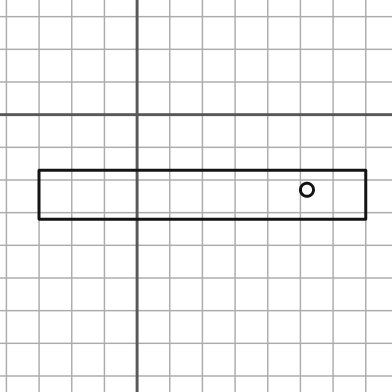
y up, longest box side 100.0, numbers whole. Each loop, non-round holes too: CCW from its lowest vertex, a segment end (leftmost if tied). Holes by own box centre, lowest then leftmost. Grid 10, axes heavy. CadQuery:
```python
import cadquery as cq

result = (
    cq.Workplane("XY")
    .moveTo(-30.0, -32.0)
    .lineTo(70.0, -32.0)
    .lineTo(70.0, -17.0)
    .lineTo(-30.0, -17.0)
    .close()
    .moveTo(52.0, -23.0)
    .circle(2.0)
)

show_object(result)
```